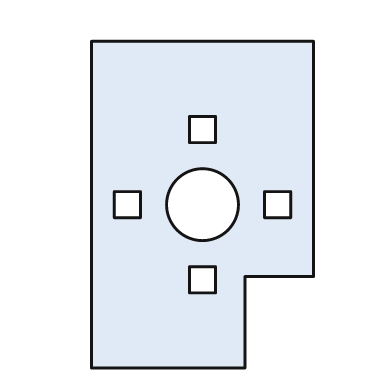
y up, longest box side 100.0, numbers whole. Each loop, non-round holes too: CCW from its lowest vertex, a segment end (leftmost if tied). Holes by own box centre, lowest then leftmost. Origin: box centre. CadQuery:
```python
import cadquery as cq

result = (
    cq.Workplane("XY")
    .moveTo(-34.0, -50.0)
    .lineTo(13.0, -50.0)
    .lineTo(13.0, -22.0)
    .lineTo(34.0, -22.0)
    .lineTo(34.0, 50.0)
    .lineTo(-34.0, 50.0)
    .close()
    .moveTo(-4.0, -27.0)
    .lineTo(4.0, -27.0)
    .lineTo(4.0, -19.0)
    .lineTo(-4.0, -19.0)
    .close()
    .moveTo(-27.0, -4.0)
    .lineTo(-19.0, -4.0)
    .lineTo(-19.0, 4.0)
    .lineTo(-27.0, 4.0)
    .close()
    .moveTo(0.0, 0.0)
    .circle(11.0)
    .moveTo(19.0, -4.0)
    .lineTo(27.0, -4.0)
    .lineTo(27.0, 4.0)
    .lineTo(19.0, 4.0)
    .close()
    .moveTo(-4.0, 19.0)
    .lineTo(4.0, 19.0)
    .lineTo(4.0, 27.0)
    .lineTo(-4.0, 27.0)
    .close()
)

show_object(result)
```